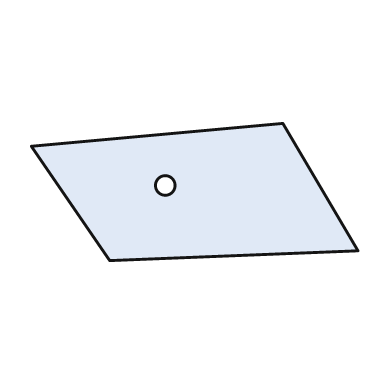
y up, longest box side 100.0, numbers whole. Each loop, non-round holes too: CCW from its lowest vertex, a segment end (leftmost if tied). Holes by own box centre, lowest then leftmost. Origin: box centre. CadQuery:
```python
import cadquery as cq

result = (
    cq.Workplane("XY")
    .moveTo(-26.0, -21.0)
    .lineTo(50.0, -18.0)
    .lineTo(27.0, 21.0)
    .lineTo(-50.0, 14.0)
    .close()
    .moveTo(-9.0, 2.0)
    .circle(3.0)
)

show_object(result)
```